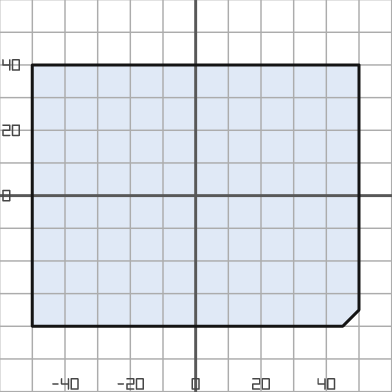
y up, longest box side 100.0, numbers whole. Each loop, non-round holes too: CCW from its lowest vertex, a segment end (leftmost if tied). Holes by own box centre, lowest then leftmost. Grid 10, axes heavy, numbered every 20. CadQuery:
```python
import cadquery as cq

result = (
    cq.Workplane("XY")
    .moveTo(-50.0, -40.0)
    .lineTo(45.0, -40.0)
    .lineTo(50.0, -35.0)
    .lineTo(50.0, 40.0)
    .lineTo(-50.0, 40.0)
    .close()
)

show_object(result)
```